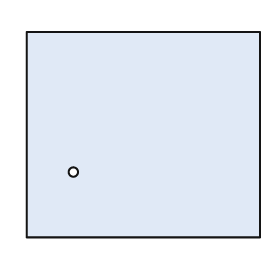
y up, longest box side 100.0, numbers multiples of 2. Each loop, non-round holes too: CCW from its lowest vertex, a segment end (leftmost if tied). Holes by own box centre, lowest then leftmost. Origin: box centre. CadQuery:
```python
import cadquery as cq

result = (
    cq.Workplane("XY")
    .moveTo(-50.0, -44.0)
    .lineTo(50.0, -44.0)
    .lineTo(50.0, 44.0)
    .lineTo(-50.0, 44.0)
    .close()
    .moveTo(-30.0, -16.0)
    .circle(2.0)
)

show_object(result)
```